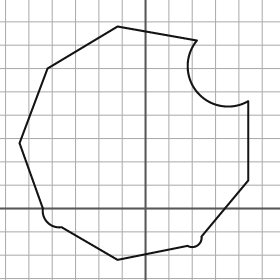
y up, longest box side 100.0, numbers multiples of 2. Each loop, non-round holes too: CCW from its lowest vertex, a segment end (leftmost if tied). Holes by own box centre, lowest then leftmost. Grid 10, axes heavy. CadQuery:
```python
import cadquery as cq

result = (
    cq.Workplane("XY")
    .moveTo(-12.0, -22.0)
    .lineTo(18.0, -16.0)
    .threePointArc((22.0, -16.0), (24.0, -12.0))
    .lineTo(44.0, 12.0)
    .lineTo(44.0, 46.0)
    .threePointArc((22.0, 50.0), (22.0, 72.0))
    .lineTo(-12.0, 78.0)
    .lineTo(-42.0, 60.0)
    .lineTo(-54.0, 28.0)
    .lineTo(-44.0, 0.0)
    .threePointArc((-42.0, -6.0), (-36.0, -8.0))
    .close()
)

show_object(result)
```